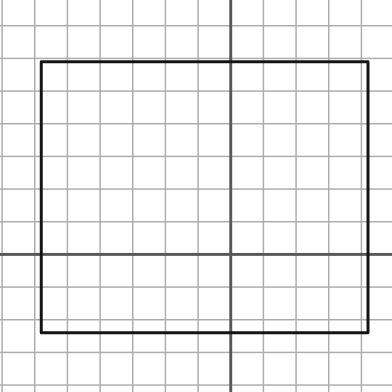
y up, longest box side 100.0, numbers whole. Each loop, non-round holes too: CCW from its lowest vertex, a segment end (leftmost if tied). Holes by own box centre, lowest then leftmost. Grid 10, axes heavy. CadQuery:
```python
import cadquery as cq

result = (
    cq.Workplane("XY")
    .moveTo(-58.0, -24.0)
    .lineTo(42.0, -24.0)
    .lineTo(42.0, 59.0)
    .lineTo(-58.0, 59.0)
    .close()
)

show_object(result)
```